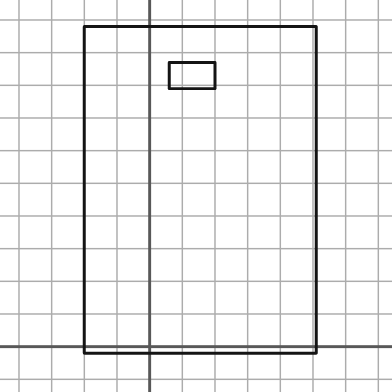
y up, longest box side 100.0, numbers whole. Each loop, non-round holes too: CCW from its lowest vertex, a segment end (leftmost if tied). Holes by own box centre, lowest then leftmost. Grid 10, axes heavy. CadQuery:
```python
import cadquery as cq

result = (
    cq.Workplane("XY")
    .moveTo(-20.0, -2.0)
    .lineTo(51.0, -2.0)
    .lineTo(51.0, 98.0)
    .lineTo(-20.0, 98.0)
    .close()
    .moveTo(6.0, 79.0)
    .lineTo(20.0, 79.0)
    .lineTo(20.0, 87.0)
    .lineTo(6.0, 87.0)
    .close()
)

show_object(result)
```